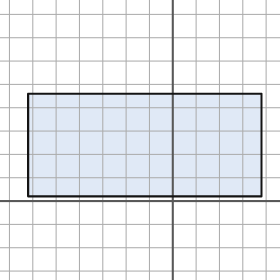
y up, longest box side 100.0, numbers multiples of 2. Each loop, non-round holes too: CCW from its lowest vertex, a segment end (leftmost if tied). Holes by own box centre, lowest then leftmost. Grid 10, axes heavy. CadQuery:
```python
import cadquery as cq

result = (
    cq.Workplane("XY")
    .moveTo(-62.0, 2.0)
    .lineTo(38.0, 2.0)
    .lineTo(38.0, 46.0)
    .lineTo(-62.0, 46.0)
    .close()
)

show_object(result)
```